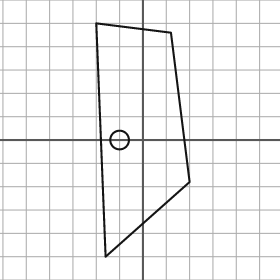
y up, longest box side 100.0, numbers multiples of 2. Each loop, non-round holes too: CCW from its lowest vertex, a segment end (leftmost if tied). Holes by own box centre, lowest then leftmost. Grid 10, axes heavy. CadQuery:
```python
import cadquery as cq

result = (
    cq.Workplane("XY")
    .moveTo(-16.0, -50.0)
    .lineTo(20.0, -18.0)
    .lineTo(12.0, 46.0)
    .lineTo(-20.0, 50.0)
    .close()
    .moveTo(-10.0, 0.0)
    .circle(4.0)
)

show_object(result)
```